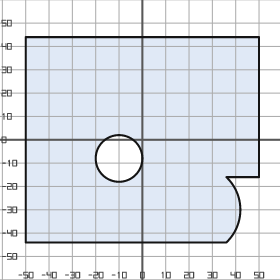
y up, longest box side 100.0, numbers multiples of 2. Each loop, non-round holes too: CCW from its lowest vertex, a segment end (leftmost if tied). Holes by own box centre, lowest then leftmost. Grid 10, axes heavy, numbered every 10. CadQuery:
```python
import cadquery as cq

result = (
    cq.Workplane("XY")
    .moveTo(-50.0, -44.0)
    .lineTo(36.0, -44.0)
    .threePointArc((42.0, -30.0), (36.0, -16.0))
    .lineTo(50.0, -16.0)
    .lineTo(50.0, 44.0)
    .lineTo(-50.0, 44.0)
    .close()
    .moveTo(-10.0, -8.0)
    .circle(10.0)
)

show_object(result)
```